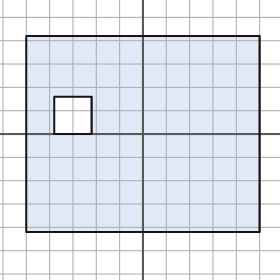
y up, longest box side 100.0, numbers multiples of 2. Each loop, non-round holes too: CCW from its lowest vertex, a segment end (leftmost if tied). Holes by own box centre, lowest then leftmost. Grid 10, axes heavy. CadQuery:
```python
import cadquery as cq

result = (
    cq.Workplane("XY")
    .moveTo(-50.0, -42.0)
    .lineTo(50.0, -42.0)
    .lineTo(50.0, 42.0)
    .lineTo(-50.0, 42.0)
    .close()
    .moveTo(-38.0, 0.0)
    .lineTo(-22.0, 0.0)
    .lineTo(-22.0, 16.0)
    .lineTo(-38.0, 16.0)
    .close()
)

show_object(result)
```